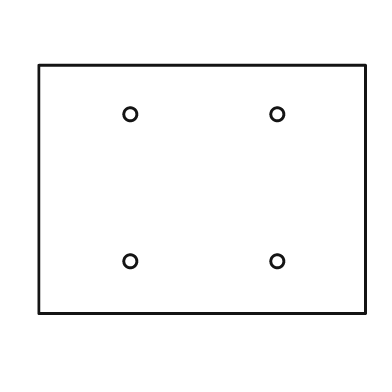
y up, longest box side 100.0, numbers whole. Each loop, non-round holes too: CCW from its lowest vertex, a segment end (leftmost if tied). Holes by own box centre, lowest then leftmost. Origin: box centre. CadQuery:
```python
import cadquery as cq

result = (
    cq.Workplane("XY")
    .moveTo(-50.0, -38.0)
    .lineTo(50.0, -38.0)
    .lineTo(50.0, 38.0)
    .lineTo(-50.0, 38.0)
    .close()
    .moveTo(-22.0, -22.0)
    .circle(2.0)
    .moveTo(23.0, -22.0)
    .circle(2.0)
    .moveTo(-22.0, 23.0)
    .circle(2.0)
    .moveTo(23.0, 23.0)
    .circle(2.0)
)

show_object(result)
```